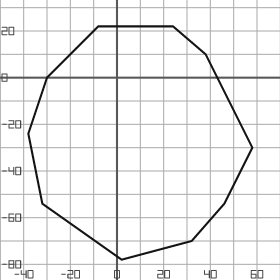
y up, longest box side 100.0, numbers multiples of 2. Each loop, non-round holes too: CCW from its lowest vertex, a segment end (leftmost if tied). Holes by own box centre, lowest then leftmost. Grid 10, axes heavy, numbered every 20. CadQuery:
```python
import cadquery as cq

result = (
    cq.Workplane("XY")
    .moveTo(2.0, -78.0)
    .lineTo(32.0, -70.0)
    .lineTo(46.0, -54.0)
    .lineTo(58.0, -30.0)
    .lineTo(38.0, 10.0)
    .lineTo(24.0, 22.0)
    .lineTo(-8.0, 22.0)
    .lineTo(-30.0, 0.0)
    .lineTo(-38.0, -24.0)
    .lineTo(-32.0, -54.0)
    .close()
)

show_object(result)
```